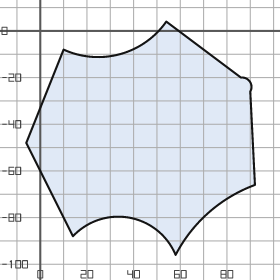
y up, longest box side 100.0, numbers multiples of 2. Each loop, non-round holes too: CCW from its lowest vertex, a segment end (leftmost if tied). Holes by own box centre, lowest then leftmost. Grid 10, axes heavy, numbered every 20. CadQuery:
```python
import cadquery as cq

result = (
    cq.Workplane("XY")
    .moveTo(58.0, -96.0)
    .threePointArc((72.0, -78.0), (92.0, -66.0))
    .lineTo(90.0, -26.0)
    .threePointArc((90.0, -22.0), (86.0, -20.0))
    .lineTo(54.0, 4.0)
    .threePointArc((34.0, -10.0), (10.0, -8.0))
    .lineTo(-6.0, -48.0)
    .lineTo(14.0, -88.0)
    .threePointArc((38.0, -80.0), (58.0, -96.0))
    .close()
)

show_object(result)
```